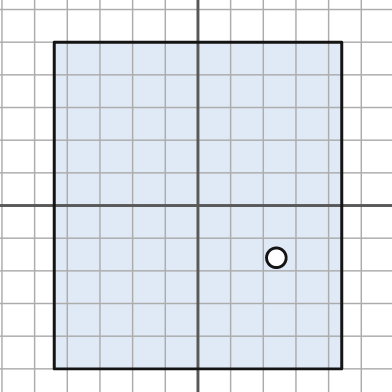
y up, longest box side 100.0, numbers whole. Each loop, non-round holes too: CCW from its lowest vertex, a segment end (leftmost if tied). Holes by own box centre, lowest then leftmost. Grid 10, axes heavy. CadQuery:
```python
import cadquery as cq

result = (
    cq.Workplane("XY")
    .moveTo(-44.0, -50.0)
    .lineTo(44.0, -50.0)
    .lineTo(44.0, 50.0)
    .lineTo(-44.0, 50.0)
    .close()
    .moveTo(24.0, -16.0)
    .circle(3.0)
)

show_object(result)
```